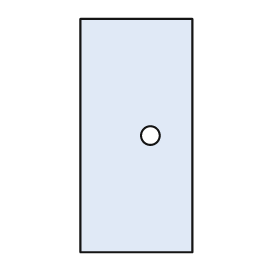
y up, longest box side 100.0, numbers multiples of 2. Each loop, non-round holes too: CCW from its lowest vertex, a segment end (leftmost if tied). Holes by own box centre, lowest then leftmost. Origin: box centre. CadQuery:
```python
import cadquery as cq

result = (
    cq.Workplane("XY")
    .moveTo(-24.0, -50.0)
    .lineTo(24.0, -50.0)
    .lineTo(24.0, 50.0)
    .lineTo(-24.0, 50.0)
    .close()
    .moveTo(6.0, 0.0)
    .circle(4.0)
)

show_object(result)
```